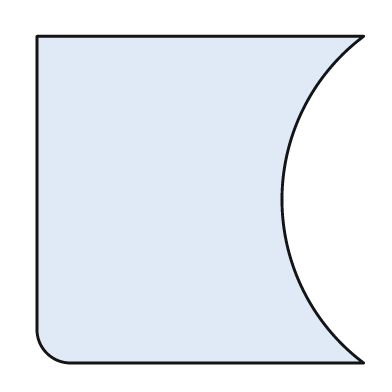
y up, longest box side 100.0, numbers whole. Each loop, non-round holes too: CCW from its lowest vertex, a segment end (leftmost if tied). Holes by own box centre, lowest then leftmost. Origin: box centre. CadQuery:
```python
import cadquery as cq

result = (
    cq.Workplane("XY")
    .moveTo(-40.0, -50.0)
    .lineTo(50.0, -50.0)
    .threePointArc((25.0, 0.0), (50.0, 50.0))
    .lineTo(-50.0, 50.0)
    .lineTo(-50.0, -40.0)
    .threePointArc((-47.0, -47.0), (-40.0, -50.0))
    .close()
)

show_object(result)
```